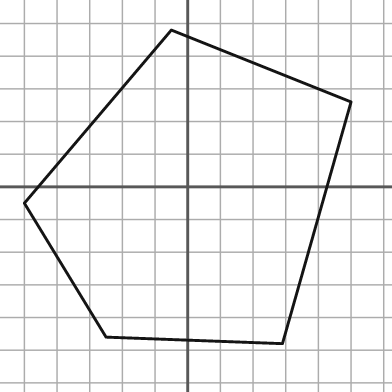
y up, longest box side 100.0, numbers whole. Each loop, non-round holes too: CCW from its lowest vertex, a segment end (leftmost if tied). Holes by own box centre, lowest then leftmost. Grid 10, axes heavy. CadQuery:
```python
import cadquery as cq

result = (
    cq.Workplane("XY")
    .moveTo(29.0, -48.0)
    .lineTo(50.0, 26.0)
    .lineTo(-5.0, 48.0)
    .lineTo(-50.0, -5.0)
    .lineTo(-25.0, -46.0)
    .close()
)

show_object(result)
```